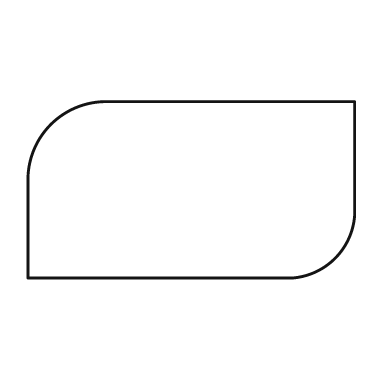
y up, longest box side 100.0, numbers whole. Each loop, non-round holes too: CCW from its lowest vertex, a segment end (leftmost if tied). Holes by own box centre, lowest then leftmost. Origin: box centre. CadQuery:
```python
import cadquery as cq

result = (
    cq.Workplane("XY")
    .moveTo(-50.0, -27.0)
    .lineTo(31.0, -27.0)
    .threePointArc((44.0, -21.0), (50.0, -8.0))
    .lineTo(50.0, 27.0)
    .lineTo(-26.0, 27.0)
    .threePointArc((-43.0, 20.0), (-50.0, 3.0))
    .close()
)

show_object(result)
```